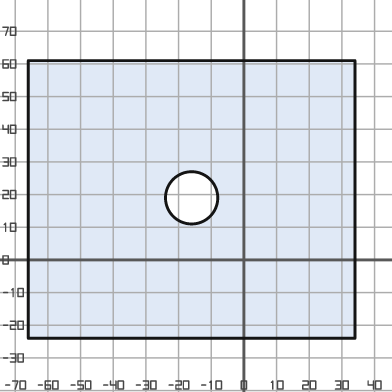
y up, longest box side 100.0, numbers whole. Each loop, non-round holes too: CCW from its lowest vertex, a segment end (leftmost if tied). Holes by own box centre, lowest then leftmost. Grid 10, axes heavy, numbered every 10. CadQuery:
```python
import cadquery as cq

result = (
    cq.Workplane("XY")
    .moveTo(-66.0, -24.0)
    .lineTo(34.0, -24.0)
    .lineTo(34.0, 61.0)
    .lineTo(-66.0, 61.0)
    .close()
    .moveTo(-16.0, 19.0)
    .circle(8.0)
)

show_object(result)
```